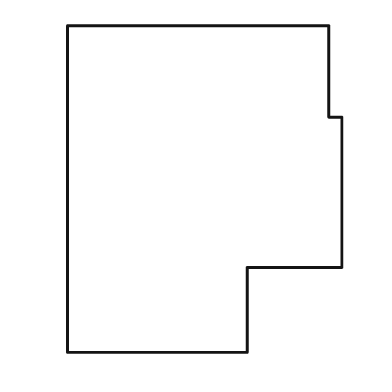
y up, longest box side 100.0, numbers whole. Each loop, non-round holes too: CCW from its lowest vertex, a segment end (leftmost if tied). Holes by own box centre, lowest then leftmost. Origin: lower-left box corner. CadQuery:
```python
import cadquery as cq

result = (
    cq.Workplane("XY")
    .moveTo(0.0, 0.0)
    .lineTo(55.0, 0.0)
    .lineTo(55.0, 26.0)
    .lineTo(84.0, 26.0)
    .lineTo(84.0, 72.0)
    .lineTo(80.0, 72.0)
    .lineTo(80.0, 100.0)
    .lineTo(0.0, 100.0)
    .close()
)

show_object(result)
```